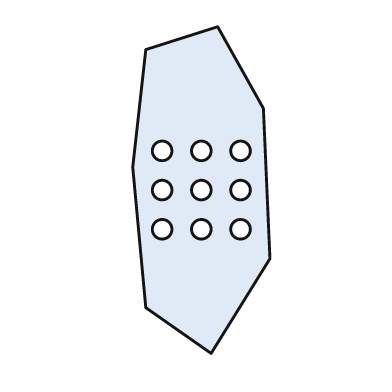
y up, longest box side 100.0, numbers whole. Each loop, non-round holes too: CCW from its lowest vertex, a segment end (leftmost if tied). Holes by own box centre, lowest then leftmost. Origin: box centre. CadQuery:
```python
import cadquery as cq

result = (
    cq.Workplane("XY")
    .moveTo(3.0, -50.0)
    .lineTo(21.0, -21.0)
    .lineTo(19.0, 25.0)
    .lineTo(5.0, 50.0)
    .lineTo(-17.0, 43.0)
    .lineTo(-21.0, 7.0)
    .lineTo(-17.0, -36.0)
    .close()
    .moveTo(-12.0, -12.0)
    .circle(3.0)
    .moveTo(0.0, -12.0)
    .circle(3.0)
    .moveTo(12.0, -12.0)
    .circle(3.0)
    .moveTo(-12.0, 0.0)
    .circle(3.0)
    .moveTo(0.0, 0.0)
    .circle(3.0)
    .moveTo(12.0, 0.0)
    .circle(3.0)
    .moveTo(-12.0, 12.0)
    .circle(3.0)
    .moveTo(0.0, 12.0)
    .circle(3.0)
    .moveTo(12.0, 12.0)
    .circle(3.0)
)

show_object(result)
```